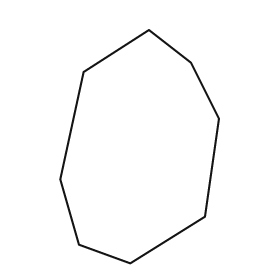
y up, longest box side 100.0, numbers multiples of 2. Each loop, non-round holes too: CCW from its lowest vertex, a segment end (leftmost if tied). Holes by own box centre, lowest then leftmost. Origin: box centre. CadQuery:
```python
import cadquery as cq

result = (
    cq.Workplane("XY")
    .moveTo(-4.0, -50.0)
    .lineTo(28.0, -30.0)
    .lineTo(34.0, 12.0)
    .lineTo(22.0, 36.0)
    .lineTo(4.0, 50.0)
    .lineTo(-24.0, 32.0)
    .lineTo(-34.0, -14.0)
    .lineTo(-26.0, -42.0)
    .close()
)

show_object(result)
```